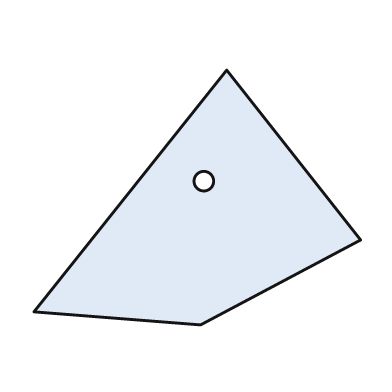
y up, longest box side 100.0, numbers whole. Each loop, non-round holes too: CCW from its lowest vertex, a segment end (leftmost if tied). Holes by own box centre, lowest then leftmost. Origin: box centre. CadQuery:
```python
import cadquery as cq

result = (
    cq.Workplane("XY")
    .moveTo(1.0, -39.0)
    .lineTo(50.0, -13.0)
    .lineTo(9.0, 39.0)
    .lineTo(-50.0, -35.0)
    .close()
    .moveTo(2.0, 5.0)
    .circle(3.0)
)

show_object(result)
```